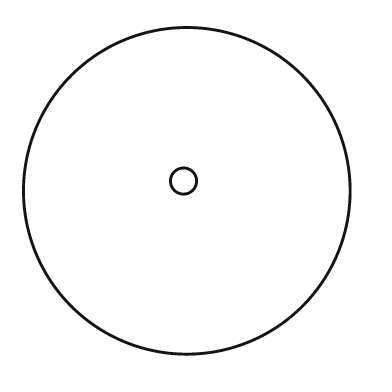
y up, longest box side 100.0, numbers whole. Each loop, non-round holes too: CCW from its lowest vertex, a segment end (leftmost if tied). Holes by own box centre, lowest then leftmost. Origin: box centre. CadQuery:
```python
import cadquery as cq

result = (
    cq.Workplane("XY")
    .moveTo(0.0, 0.0)
    .circle(50.0)
    .moveTo(-1.0, 3.0)
    .circle(4.0)
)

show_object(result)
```